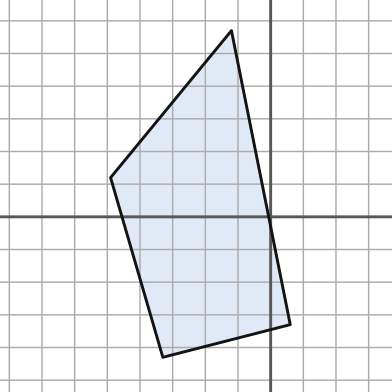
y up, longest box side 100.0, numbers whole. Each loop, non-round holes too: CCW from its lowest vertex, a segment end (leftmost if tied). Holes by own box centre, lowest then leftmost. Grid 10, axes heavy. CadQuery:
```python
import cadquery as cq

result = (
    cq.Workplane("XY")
    .moveTo(-33.0, -43.0)
    .lineTo(6.0, -33.0)
    .lineTo(-12.0, 57.0)
    .lineTo(-49.0, 12.0)
    .close()
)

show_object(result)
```